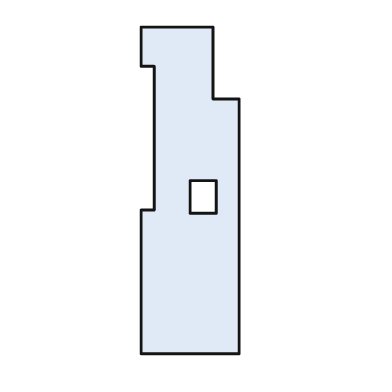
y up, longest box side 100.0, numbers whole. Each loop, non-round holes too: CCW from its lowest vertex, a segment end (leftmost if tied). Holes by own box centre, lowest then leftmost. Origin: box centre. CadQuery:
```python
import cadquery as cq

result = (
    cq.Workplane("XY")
    .moveTo(-15.0, -50.0)
    .lineTo(15.0, -50.0)
    .lineTo(15.0, 28.0)
    .lineTo(7.0, 28.0)
    .lineTo(7.0, 50.0)
    .lineTo(-15.0, 50.0)
    .lineTo(-15.0, 38.0)
    .lineTo(-11.0, 38.0)
    .lineTo(-11.0, -6.0)
    .lineTo(-15.0, -6.0)
    .close()
    .moveTo(0.0, -7.0)
    .lineTo(8.0, -7.0)
    .lineTo(8.0, 3.0)
    .lineTo(0.0, 3.0)
    .close()
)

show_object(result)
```